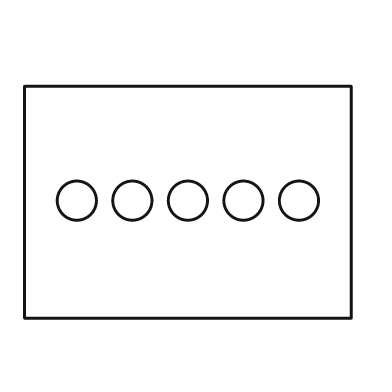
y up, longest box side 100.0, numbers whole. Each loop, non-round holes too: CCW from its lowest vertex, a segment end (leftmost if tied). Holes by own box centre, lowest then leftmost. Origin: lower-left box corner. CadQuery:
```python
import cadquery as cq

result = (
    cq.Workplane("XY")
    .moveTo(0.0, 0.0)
    .lineTo(100.0, 0.0)
    .lineTo(100.0, 71.0)
    .lineTo(0.0, 71.0)
    .close()
    .moveTo(16.0, 36.0)
    .circle(6.0)
    .moveTo(33.0, 36.0)
    .circle(6.0)
    .moveTo(50.0, 36.0)
    .circle(6.0)
    .moveTo(67.0, 36.0)
    .circle(6.0)
    .moveTo(84.0, 36.0)
    .circle(6.0)
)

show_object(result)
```